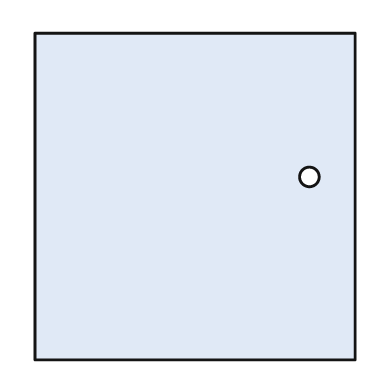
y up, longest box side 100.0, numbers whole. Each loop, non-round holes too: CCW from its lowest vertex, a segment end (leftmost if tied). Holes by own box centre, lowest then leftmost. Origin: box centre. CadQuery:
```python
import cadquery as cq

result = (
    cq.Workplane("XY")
    .moveTo(-49.0, -50.0)
    .lineTo(49.0, -50.0)
    .lineTo(49.0, 50.0)
    .lineTo(-49.0, 50.0)
    .close()
    .moveTo(35.0, 6.0)
    .circle(3.0)
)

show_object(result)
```